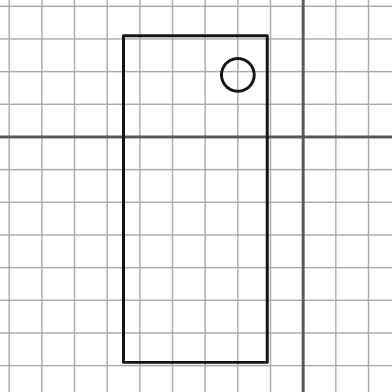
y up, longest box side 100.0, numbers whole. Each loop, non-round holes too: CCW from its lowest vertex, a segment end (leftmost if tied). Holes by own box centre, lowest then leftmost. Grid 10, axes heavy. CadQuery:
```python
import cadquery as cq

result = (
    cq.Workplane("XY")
    .moveTo(-55.0, -69.0)
    .lineTo(-11.0, -69.0)
    .lineTo(-11.0, 31.0)
    .lineTo(-55.0, 31.0)
    .close()
    .moveTo(-20.0, 19.0)
    .circle(5.0)
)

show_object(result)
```